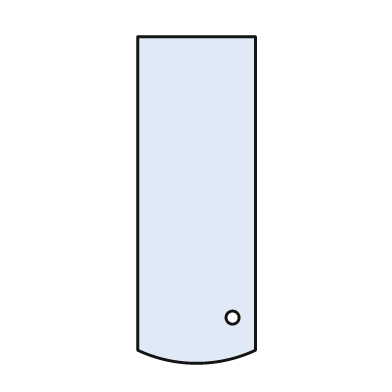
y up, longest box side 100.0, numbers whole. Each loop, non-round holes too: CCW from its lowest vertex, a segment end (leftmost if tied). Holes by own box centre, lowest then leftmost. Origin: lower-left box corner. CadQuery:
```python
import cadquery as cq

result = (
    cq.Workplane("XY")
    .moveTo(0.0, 4.0)
    .threePointArc((18.0, 0.0), (36.0, 4.0))
    .lineTo(36.0, 100.0)
    .lineTo(0.0, 100.0)
    .close()
    .moveTo(29.0, 14.0)
    .circle(2.0)
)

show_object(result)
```